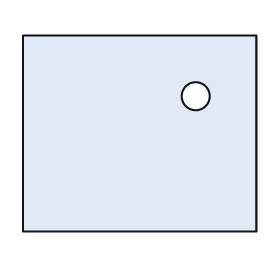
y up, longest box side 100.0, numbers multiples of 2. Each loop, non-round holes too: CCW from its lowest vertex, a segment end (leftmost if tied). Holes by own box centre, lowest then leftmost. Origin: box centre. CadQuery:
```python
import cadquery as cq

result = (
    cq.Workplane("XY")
    .moveTo(-50.0, -42.0)
    .lineTo(50.0, -42.0)
    .lineTo(50.0, 42.0)
    .lineTo(-50.0, 42.0)
    .close()
    .moveTo(24.0, 16.0)
    .circle(6.0)
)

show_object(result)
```